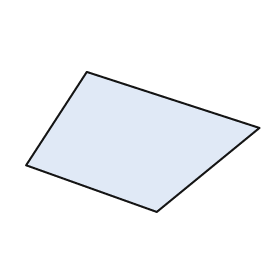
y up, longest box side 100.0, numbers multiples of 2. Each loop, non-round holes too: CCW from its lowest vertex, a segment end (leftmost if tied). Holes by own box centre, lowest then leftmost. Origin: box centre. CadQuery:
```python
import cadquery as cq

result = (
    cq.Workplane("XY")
    .moveTo(6.0, -30.0)
    .lineTo(50.0, 6.0)
    .lineTo(-24.0, 30.0)
    .lineTo(-50.0, -10.0)
    .close()
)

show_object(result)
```